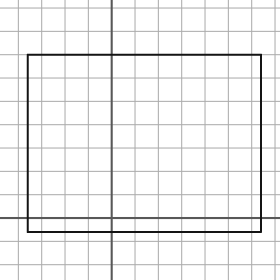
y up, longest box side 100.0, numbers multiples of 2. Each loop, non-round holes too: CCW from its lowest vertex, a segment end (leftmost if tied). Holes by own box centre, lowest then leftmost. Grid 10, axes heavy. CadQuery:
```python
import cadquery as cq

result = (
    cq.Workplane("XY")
    .moveTo(-36.0, -6.0)
    .lineTo(64.0, -6.0)
    .lineTo(64.0, 70.0)
    .lineTo(-36.0, 70.0)
    .close()
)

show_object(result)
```